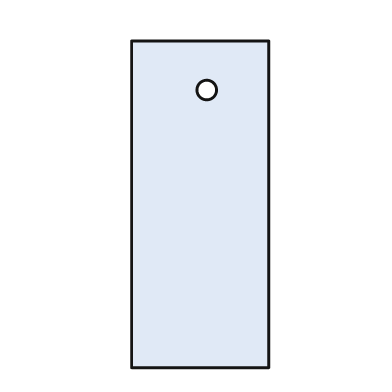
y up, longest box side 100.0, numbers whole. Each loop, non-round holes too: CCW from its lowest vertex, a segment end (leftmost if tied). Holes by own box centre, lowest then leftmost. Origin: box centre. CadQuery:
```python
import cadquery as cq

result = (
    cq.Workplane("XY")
    .moveTo(-21.0, -50.0)
    .lineTo(21.0, -50.0)
    .lineTo(21.0, 50.0)
    .lineTo(-21.0, 50.0)
    .close()
    .moveTo(2.0, 35.0)
    .circle(3.0)
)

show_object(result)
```